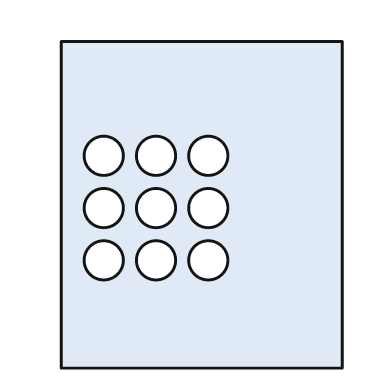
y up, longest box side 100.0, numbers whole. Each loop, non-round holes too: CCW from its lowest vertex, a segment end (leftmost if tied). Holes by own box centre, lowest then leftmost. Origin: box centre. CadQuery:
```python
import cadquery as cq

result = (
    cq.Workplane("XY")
    .moveTo(-43.0, -50.0)
    .lineTo(43.0, -50.0)
    .lineTo(43.0, 50.0)
    .lineTo(-43.0, 50.0)
    .close()
    .moveTo(-30.0, -17.0)
    .circle(6.0)
    .moveTo(-14.0, -17.0)
    .circle(6.0)
    .moveTo(2.0, -17.0)
    .circle(6.0)
    .moveTo(-30.0, -1.0)
    .circle(6.0)
    .moveTo(-14.0, -1.0)
    .circle(6.0)
    .moveTo(2.0, -1.0)
    .circle(6.0)
    .moveTo(-30.0, 15.0)
    .circle(6.0)
    .moveTo(-14.0, 15.0)
    .circle(6.0)
    .moveTo(2.0, 15.0)
    .circle(6.0)
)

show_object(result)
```